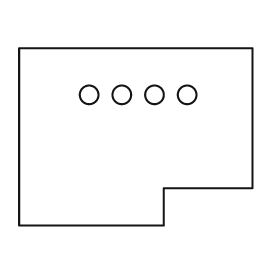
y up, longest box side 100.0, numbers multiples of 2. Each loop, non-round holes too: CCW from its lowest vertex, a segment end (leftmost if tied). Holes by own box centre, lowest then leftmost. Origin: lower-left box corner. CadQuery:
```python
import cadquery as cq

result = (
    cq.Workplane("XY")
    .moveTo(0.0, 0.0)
    .lineTo(62.0, 0.0)
    .lineTo(62.0, 16.0)
    .lineTo(100.0, 16.0)
    .lineTo(100.0, 76.0)
    .lineTo(0.0, 76.0)
    .close()
    .moveTo(30.0, 56.0)
    .circle(4.0)
    .moveTo(44.0, 56.0)
    .circle(4.0)
    .moveTo(58.0, 56.0)
    .circle(4.0)
    .moveTo(72.0, 56.0)
    .circle(4.0)
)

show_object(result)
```